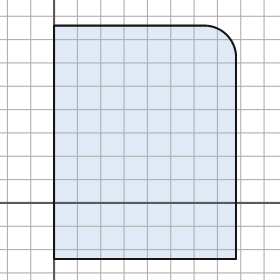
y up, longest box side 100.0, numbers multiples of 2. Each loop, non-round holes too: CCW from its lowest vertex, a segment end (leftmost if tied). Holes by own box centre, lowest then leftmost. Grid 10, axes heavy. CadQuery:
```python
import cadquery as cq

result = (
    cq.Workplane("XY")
    .moveTo(0.0, -24.0)
    .lineTo(78.0, -24.0)
    .lineTo(78.0, 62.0)
    .threePointArc((74.0, 72.0), (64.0, 76.0))
    .lineTo(0.0, 76.0)
    .close()
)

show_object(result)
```